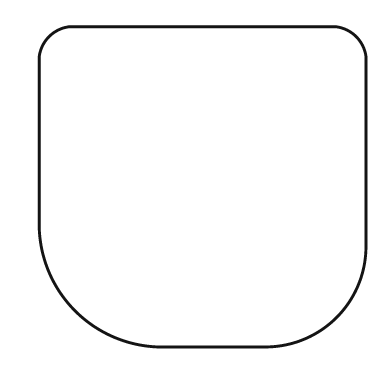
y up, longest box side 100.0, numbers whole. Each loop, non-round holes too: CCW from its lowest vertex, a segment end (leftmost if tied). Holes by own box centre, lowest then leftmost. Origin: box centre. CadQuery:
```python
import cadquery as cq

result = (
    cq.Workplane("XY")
    .moveTo(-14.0, -49.0)
    .lineTo(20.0, -49.0)
    .threePointArc((41.0, -40.0), (50.0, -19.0))
    .lineTo(50.0, 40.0)
    .threePointArc((47.0, 46.0), (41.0, 49.0))
    .lineTo(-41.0, 49.0)
    .threePointArc((-47.0, 46.0), (-50.0, 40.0))
    .lineTo(-50.0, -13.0)
    .threePointArc((-39.0, -38.0), (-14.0, -49.0))
    .close()
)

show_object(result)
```